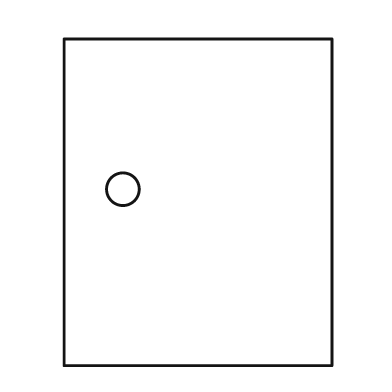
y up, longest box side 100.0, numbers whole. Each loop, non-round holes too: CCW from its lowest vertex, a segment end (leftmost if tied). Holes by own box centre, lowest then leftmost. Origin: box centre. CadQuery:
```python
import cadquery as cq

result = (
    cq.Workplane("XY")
    .moveTo(-41.0, -50.0)
    .lineTo(41.0, -50.0)
    .lineTo(41.0, 50.0)
    .lineTo(-41.0, 50.0)
    .close()
    .moveTo(-23.0, 4.0)
    .circle(5.0)
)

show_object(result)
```